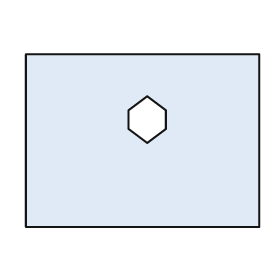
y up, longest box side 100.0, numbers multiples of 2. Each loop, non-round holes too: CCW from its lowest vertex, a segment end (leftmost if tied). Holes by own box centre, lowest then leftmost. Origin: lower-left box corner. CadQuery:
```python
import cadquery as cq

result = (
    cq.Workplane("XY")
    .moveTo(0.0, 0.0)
    .lineTo(100.0, 0.0)
    .lineTo(100.0, 74.0)
    .lineTo(0.0, 74.0)
    .close()
    .moveTo(52.0, 36.0)
    .lineTo(60.0, 42.0)
    .lineTo(60.0, 50.0)
    .lineTo(52.0, 56.0)
    .lineTo(44.0, 50.0)
    .lineTo(44.0, 42.0)
    .close()
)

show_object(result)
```